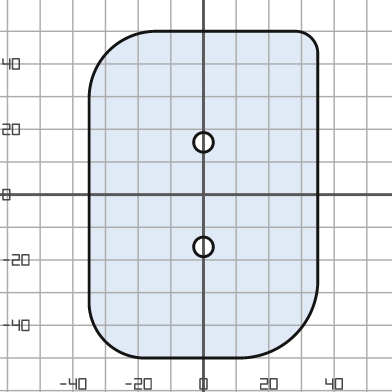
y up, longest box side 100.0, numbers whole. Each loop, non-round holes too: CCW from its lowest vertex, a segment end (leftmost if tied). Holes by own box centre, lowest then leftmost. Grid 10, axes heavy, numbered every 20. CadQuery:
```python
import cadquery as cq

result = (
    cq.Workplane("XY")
    .moveTo(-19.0, -50.0)
    .lineTo(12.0, -50.0)
    .threePointArc((28.0, -43.0), (35.0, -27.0))
    .lineTo(35.0, 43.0)
    .threePointArc((33.0, 48.0), (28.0, 50.0))
    .lineTo(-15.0, 50.0)
    .threePointArc((-29.0, 44.0), (-35.0, 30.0))
    .lineTo(-35.0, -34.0)
    .threePointArc((-30.0, -45.0), (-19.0, -50.0))
    .close()
    .moveTo(0.0, -16.0)
    .circle(3.0)
    .moveTo(0.0, 16.0)
    .circle(3.0)
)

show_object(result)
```